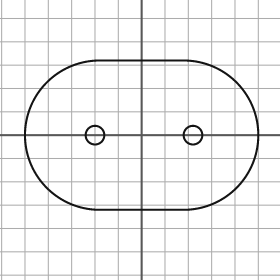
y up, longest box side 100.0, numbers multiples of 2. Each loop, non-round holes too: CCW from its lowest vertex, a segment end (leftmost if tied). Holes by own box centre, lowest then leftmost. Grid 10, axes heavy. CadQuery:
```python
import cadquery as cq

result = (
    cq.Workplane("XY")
    .moveTo(-18.0, -32.0)
    .lineTo(18.0, -32.0)
    .threePointArc((50.0, 0.0), (18.0, 32.0))
    .lineTo(-18.0, 32.0)
    .threePointArc((-50.0, 0.0), (-18.0, -32.0))
    .close()
    .moveTo(-20.0, 0.0)
    .circle(4.0)
    .moveTo(22.0, 0.0)
    .circle(4.0)
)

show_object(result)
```